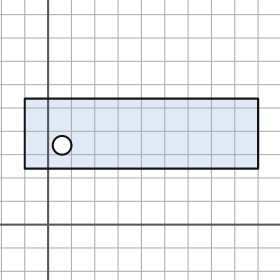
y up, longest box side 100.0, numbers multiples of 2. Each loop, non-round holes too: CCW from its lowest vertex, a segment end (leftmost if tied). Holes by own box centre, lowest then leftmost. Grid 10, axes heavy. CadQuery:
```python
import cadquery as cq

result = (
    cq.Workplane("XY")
    .moveTo(-10.0, 24.0)
    .lineTo(90.0, 24.0)
    .lineTo(90.0, 54.0)
    .lineTo(-10.0, 54.0)
    .close()
    .moveTo(6.0, 34.0)
    .circle(4.0)
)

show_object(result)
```